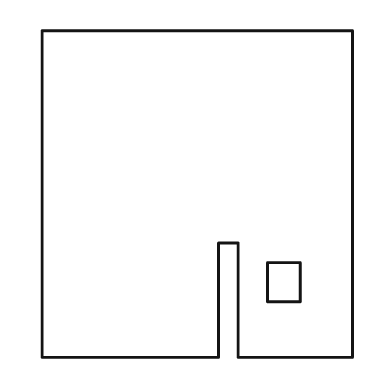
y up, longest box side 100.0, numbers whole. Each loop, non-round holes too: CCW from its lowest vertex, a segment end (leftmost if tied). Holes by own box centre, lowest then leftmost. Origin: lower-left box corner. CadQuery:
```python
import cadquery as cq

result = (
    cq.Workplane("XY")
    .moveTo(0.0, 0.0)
    .lineTo(54.0, 0.0)
    .lineTo(54.0, 35.0)
    .lineTo(60.0, 35.0)
    .lineTo(60.0, 0.0)
    .lineTo(95.0, 0.0)
    .lineTo(95.0, 100.0)
    .lineTo(0.0, 100.0)
    .close()
    .moveTo(69.0, 17.0)
    .lineTo(79.0, 17.0)
    .lineTo(79.0, 29.0)
    .lineTo(69.0, 29.0)
    .close()
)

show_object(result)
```